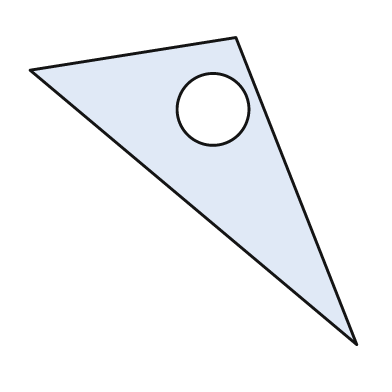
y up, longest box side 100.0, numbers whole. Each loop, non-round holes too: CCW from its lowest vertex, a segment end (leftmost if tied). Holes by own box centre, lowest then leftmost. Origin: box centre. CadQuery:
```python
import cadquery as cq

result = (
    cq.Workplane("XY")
    .moveTo(50.0, -47.0)
    .lineTo(13.0, 47.0)
    .lineTo(-50.0, 37.0)
    .close()
    .moveTo(6.0, 25.0)
    .circle(11.0)
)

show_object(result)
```